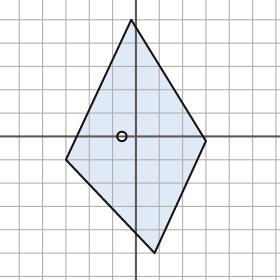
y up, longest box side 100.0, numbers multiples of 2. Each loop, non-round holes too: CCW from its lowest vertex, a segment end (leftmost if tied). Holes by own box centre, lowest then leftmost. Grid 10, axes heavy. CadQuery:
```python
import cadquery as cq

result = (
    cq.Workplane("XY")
    .moveTo(8.0, -50.0)
    .lineTo(30.0, -2.0)
    .lineTo(-2.0, 50.0)
    .lineTo(-30.0, -10.0)
    .close()
    .moveTo(-6.0, 0.0)
    .circle(2.0)
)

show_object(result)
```